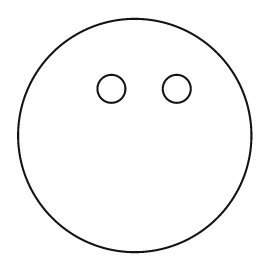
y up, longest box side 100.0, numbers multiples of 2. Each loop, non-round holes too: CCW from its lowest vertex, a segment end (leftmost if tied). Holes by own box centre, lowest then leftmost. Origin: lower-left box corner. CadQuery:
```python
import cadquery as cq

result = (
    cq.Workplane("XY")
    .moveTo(50.0, 50.0)
    .circle(50.0)
    .moveTo(40.0, 70.0)
    .circle(6.0)
    .moveTo(68.0, 70.0)
    .circle(6.0)
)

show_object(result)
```